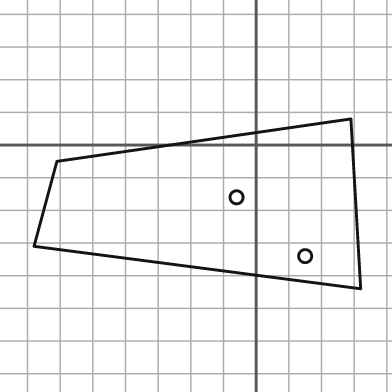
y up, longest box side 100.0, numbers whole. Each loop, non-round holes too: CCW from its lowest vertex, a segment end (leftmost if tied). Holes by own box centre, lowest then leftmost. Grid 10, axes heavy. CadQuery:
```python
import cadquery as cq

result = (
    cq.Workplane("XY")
    .moveTo(32.0, -44.0)
    .lineTo(29.0, 8.0)
    .lineTo(-61.0, -5.0)
    .lineTo(-68.0, -31.0)
    .close()
    .moveTo(15.0, -34.0)
    .circle(2.0)
    .moveTo(-6.0, -16.0)
    .circle(2.0)
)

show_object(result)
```